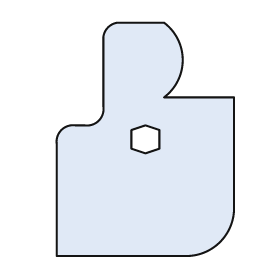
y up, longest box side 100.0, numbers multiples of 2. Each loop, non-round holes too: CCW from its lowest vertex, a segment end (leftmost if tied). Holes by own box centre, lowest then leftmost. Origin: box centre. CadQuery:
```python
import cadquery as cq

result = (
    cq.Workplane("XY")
    .moveTo(-38.0, -50.0)
    .lineTo(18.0, -50.0)
    .threePointArc((32.0, -44.0), (38.0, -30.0))
    .lineTo(38.0, 18.0)
    .lineTo(8.0, 18.0)
    .threePointArc((16.0, 34.0), (8.0, 50.0))
    .lineTo(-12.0, 50.0)
    .threePointArc((-16.0, 48.0), (-18.0, 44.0))
    .lineTo(-18.0, 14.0)
    .threePointArc((-20.0, 8.0), (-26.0, 6.0))
    .lineTo(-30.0, 6.0)
    .threePointArc((-36.0, 4.0), (-38.0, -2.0))
    .close()
    .moveTo(0.0, -6.0)
    .lineTo(6.0, -4.0)
    .lineTo(6.0, 4.0)
    .lineTo(0.0, 6.0)
    .lineTo(-6.0, 4.0)
    .lineTo(-6.0, -4.0)
    .close()
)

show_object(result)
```